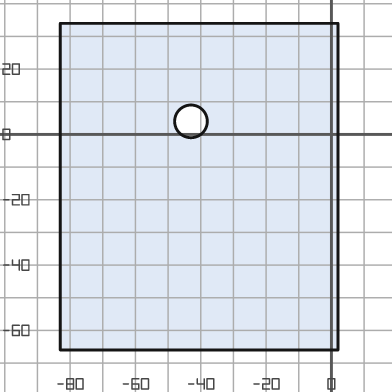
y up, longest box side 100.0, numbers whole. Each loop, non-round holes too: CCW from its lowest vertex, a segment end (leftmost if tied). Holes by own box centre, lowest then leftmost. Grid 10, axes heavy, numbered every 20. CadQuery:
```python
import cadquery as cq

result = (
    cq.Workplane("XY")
    .moveTo(-83.0, -66.0)
    .lineTo(2.0, -66.0)
    .lineTo(2.0, 34.0)
    .lineTo(-83.0, 34.0)
    .close()
    .moveTo(-43.0, 4.0)
    .circle(5.0)
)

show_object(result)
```